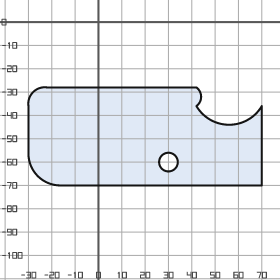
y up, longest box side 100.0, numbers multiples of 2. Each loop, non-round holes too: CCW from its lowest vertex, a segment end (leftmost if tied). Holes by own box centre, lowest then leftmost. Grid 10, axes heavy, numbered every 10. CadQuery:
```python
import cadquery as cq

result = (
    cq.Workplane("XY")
    .moveTo(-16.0, -70.0)
    .lineTo(70.0, -70.0)
    .lineTo(70.0, -36.0)
    .threePointArc((56.0, -44.0), (42.0, -36.0))
    .threePointArc((44.0, -32.0), (42.0, -28.0))
    .lineTo(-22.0, -28.0)
    .threePointArc((-28.0, -30.0), (-30.0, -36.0))
    .lineTo(-30.0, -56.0)
    .threePointArc((-26.0, -66.0), (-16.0, -70.0))
    .close()
    .moveTo(30.0, -60.0)
    .circle(4.0)
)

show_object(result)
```